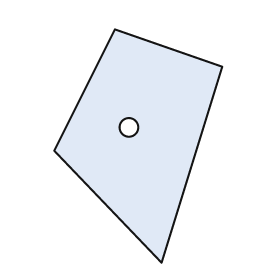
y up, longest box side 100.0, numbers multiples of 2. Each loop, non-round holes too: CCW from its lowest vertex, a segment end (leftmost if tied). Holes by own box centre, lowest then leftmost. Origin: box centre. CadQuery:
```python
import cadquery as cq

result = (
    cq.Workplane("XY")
    .moveTo(10.0, -50.0)
    .lineTo(36.0, 34.0)
    .lineTo(-10.0, 50.0)
    .lineTo(-36.0, -2.0)
    .close()
    .moveTo(-4.0, 8.0)
    .circle(4.0)
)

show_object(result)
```